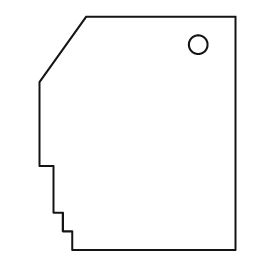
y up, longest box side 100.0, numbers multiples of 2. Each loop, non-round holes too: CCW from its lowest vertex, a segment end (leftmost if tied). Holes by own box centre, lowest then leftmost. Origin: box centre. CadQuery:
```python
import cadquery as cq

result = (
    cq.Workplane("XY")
    .moveTo(-28.0, -50.0)
    .lineTo(42.0, -50.0)
    .lineTo(42.0, 50.0)
    .lineTo(-22.0, 50.0)
    .lineTo(-42.0, 22.0)
    .lineTo(-42.0, -14.0)
    .lineTo(-36.0, -14.0)
    .lineTo(-36.0, -34.0)
    .lineTo(-32.0, -34.0)
    .lineTo(-32.0, -42.0)
    .lineTo(-28.0, -42.0)
    .close()
    .moveTo(26.0, 38.0)
    .circle(4.0)
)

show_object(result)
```